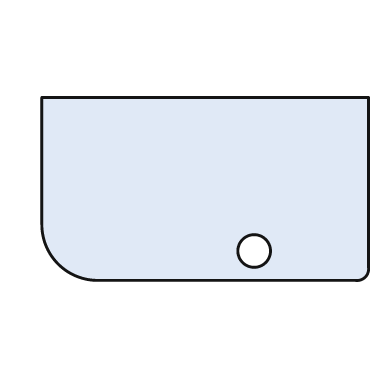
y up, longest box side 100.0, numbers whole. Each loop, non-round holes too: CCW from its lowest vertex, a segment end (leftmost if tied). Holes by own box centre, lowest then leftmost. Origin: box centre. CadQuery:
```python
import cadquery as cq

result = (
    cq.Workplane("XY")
    .moveTo(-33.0, -28.0)
    .lineTo(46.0, -28.0)
    .threePointArc((49.0, -27.0), (50.0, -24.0))
    .lineTo(50.0, 28.0)
    .lineTo(-50.0, 28.0)
    .lineTo(-50.0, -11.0)
    .threePointArc((-45.0, -23.0), (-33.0, -28.0))
    .close()
    .moveTo(15.0, -19.0)
    .circle(5.0)
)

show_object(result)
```